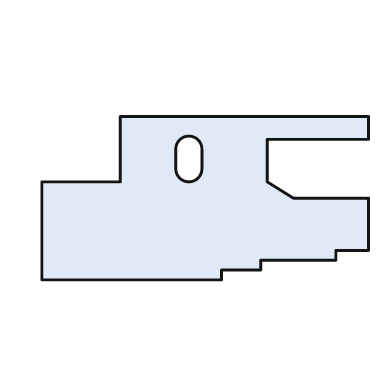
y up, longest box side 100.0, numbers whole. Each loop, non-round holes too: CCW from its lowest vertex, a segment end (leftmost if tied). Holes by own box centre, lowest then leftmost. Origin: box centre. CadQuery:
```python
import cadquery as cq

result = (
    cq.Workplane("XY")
    .moveTo(-50.0, -25.0)
    .lineTo(5.0, -25.0)
    .lineTo(5.0, -22.0)
    .lineTo(17.0, -22.0)
    .lineTo(17.0, -19.0)
    .lineTo(40.0, -19.0)
    .lineTo(40.0, -16.0)
    .lineTo(50.0, -16.0)
    .lineTo(50.0, 0.0)
    .lineTo(27.0, 0.0)
    .lineTo(19.0, 5.0)
    .lineTo(19.0, 18.0)
    .lineTo(50.0, 18.0)
    .lineTo(50.0, 25.0)
    .lineTo(-26.0, 25.0)
    .lineTo(-26.0, 5.0)
    .lineTo(-50.0, 5.0)
    .close()
    .moveTo(-9.0, 9.0)
    .threePointArc((-5.0, 5.0), (-1.0, 9.0))
    .lineTo(-1.0, 15.0)
    .threePointArc((-5.0, 19.0), (-9.0, 15.0))
    .close()
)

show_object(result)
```